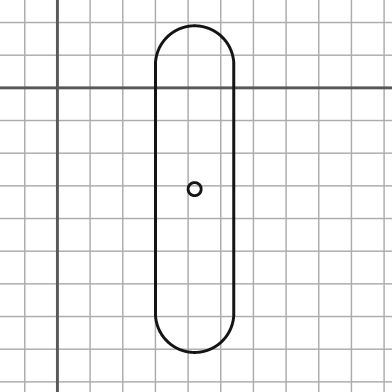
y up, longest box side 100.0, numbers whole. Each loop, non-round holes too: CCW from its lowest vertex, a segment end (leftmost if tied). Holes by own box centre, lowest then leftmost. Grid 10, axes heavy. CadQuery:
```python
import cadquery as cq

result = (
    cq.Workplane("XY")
    .moveTo(30.0, -69.0)
    .threePointArc((42.0, -81.0), (54.0, -69.0))
    .lineTo(54.0, 7.0)
    .threePointArc((42.0, 19.0), (30.0, 7.0))
    .close()
    .moveTo(42.0, -31.0)
    .circle(2.0)
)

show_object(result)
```